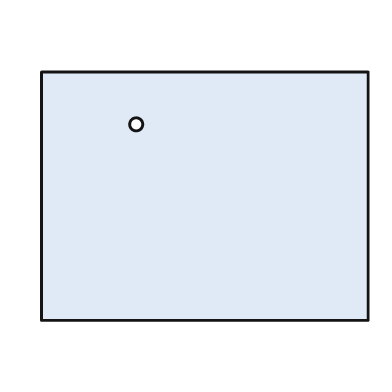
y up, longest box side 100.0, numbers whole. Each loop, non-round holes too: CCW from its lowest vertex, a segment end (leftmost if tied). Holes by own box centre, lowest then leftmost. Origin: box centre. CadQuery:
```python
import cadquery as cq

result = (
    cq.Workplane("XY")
    .moveTo(-50.0, -38.0)
    .lineTo(50.0, -38.0)
    .lineTo(50.0, 38.0)
    .lineTo(-50.0, 38.0)
    .close()
    .moveTo(-21.0, 22.0)
    .circle(2.0)
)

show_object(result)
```